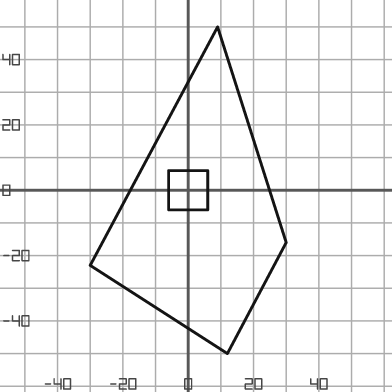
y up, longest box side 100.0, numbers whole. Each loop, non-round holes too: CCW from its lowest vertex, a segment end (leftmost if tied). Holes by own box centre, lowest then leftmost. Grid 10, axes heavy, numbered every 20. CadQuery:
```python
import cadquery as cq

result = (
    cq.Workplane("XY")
    .moveTo(12.0, -50.0)
    .lineTo(30.0, -16.0)
    .lineTo(9.0, 50.0)
    .lineTo(-30.0, -23.0)
    .close()
    .moveTo(-6.0, -6.0)
    .lineTo(6.0, -6.0)
    .lineTo(6.0, 6.0)
    .lineTo(-6.0, 6.0)
    .close()
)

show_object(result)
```